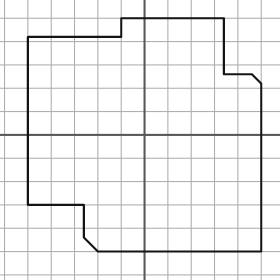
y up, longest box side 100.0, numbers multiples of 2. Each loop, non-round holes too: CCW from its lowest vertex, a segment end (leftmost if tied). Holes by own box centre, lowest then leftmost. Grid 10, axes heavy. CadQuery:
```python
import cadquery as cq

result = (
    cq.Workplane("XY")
    .moveTo(-20.0, -50.0)
    .lineTo(50.0, -50.0)
    .lineTo(50.0, 22.0)
    .lineTo(46.0, 26.0)
    .lineTo(34.0, 26.0)
    .lineTo(34.0, 50.0)
    .lineTo(-10.0, 50.0)
    .lineTo(-10.0, 42.0)
    .lineTo(-50.0, 42.0)
    .lineTo(-50.0, -30.0)
    .lineTo(-26.0, -30.0)
    .lineTo(-26.0, -44.0)
    .close()
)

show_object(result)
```